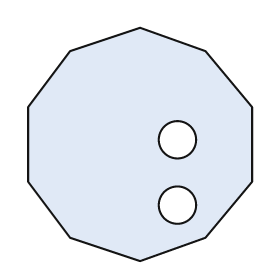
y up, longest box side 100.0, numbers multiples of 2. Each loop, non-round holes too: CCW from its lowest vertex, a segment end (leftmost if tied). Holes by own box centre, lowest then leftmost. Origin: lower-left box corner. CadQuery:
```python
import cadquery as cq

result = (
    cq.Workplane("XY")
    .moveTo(48.0, 0.0)
    .lineTo(76.0, 10.0)
    .lineTo(96.0, 34.0)
    .lineTo(96.0, 66.0)
    .lineTo(76.0, 90.0)
    .lineTo(48.0, 100.0)
    .lineTo(18.0, 90.0)
    .lineTo(0.0, 66.0)
    .lineTo(0.0, 34.0)
    .lineTo(18.0, 10.0)
    .close()
    .moveTo(64.0, 24.0)
    .circle(8.0)
    .moveTo(64.0, 52.0)
    .circle(8.0)
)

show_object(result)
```